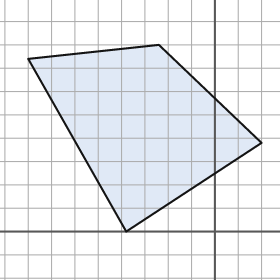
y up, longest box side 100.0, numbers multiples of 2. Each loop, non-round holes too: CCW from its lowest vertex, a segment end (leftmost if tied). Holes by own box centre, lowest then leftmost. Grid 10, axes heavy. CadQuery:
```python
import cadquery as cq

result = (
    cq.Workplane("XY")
    .moveTo(-38.0, 0.0)
    .lineTo(20.0, 38.0)
    .lineTo(-24.0, 80.0)
    .lineTo(-80.0, 74.0)
    .close()
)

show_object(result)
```